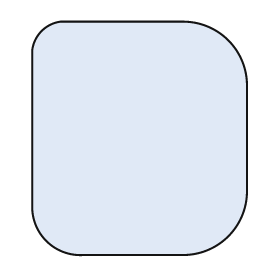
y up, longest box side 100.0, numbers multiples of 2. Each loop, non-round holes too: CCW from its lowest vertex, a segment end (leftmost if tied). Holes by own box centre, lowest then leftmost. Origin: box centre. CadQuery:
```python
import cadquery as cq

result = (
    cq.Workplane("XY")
    .moveTo(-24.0, -50.0)
    .lineTo(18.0, -50.0)
    .threePointArc((38.0, -42.0), (46.0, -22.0))
    .lineTo(46.0, 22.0)
    .threePointArc((38.0, 42.0), (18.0, 50.0))
    .lineTo(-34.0, 50.0)
    .threePointArc((-42.0, 46.0), (-46.0, 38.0))
    .lineTo(-46.0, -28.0)
    .threePointArc((-40.0, -44.0), (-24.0, -50.0))
    .close()
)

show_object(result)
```